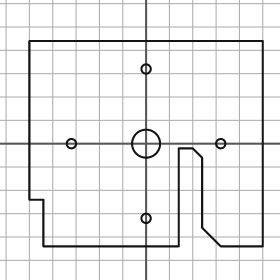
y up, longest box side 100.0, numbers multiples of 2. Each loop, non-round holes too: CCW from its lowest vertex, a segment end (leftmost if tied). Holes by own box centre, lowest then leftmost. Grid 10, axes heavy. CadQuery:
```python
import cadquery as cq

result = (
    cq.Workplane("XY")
    .moveTo(-44.0, -44.0)
    .lineTo(14.0, -44.0)
    .lineTo(14.0, -2.0)
    .lineTo(20.0, -2.0)
    .lineTo(24.0, -6.0)
    .lineTo(24.0, -36.0)
    .lineTo(32.0, -44.0)
    .lineTo(50.0, -44.0)
    .lineTo(50.0, 44.0)
    .lineTo(-50.0, 44.0)
    .lineTo(-50.0, -24.0)
    .lineTo(-44.0, -24.0)
    .close()
    .moveTo(0.0, -32.0)
    .circle(2.0)
    .moveTo(-32.0, 0.0)
    .circle(2.0)
    .moveTo(0.0, 0.0)
    .circle(6.0)
    .moveTo(32.0, 0.0)
    .circle(2.0)
    .moveTo(0.0, 32.0)
    .circle(2.0)
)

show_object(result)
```